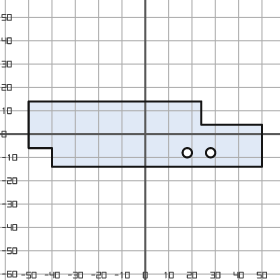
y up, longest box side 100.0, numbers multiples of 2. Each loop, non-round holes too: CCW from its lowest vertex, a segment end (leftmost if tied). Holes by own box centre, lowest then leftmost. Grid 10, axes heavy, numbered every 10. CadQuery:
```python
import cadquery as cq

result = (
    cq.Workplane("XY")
    .moveTo(-40.0, -14.0)
    .lineTo(50.0, -14.0)
    .lineTo(50.0, 4.0)
    .lineTo(24.0, 4.0)
    .lineTo(24.0, 14.0)
    .lineTo(-50.0, 14.0)
    .lineTo(-50.0, -6.0)
    .lineTo(-40.0, -6.0)
    .close()
    .moveTo(18.0, -8.0)
    .circle(2.0)
    .moveTo(28.0, -8.0)
    .circle(2.0)
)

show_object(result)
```